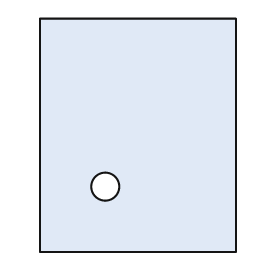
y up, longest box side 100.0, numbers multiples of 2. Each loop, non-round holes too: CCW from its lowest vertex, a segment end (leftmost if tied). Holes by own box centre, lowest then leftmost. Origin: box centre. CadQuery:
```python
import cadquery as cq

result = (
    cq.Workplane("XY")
    .moveTo(-42.0, -50.0)
    .lineTo(42.0, -50.0)
    .lineTo(42.0, 50.0)
    .lineTo(-42.0, 50.0)
    .close()
    .moveTo(-14.0, -22.0)
    .circle(6.0)
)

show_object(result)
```